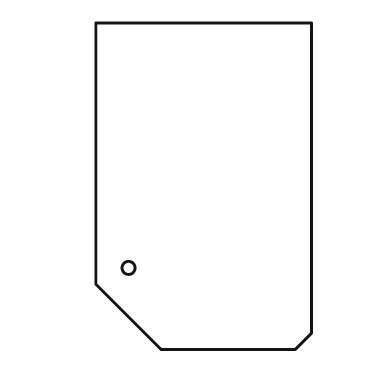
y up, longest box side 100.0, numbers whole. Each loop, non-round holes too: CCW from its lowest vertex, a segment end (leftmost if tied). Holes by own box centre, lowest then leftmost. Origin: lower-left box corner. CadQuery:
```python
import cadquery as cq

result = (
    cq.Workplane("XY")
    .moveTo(20.0, 0.0)
    .lineTo(61.0, 0.0)
    .lineTo(66.0, 5.0)
    .lineTo(66.0, 100.0)
    .lineTo(0.0, 100.0)
    .lineTo(0.0, 20.0)
    .close()
    .moveTo(10.0, 25.0)
    .circle(2.0)
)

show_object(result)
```